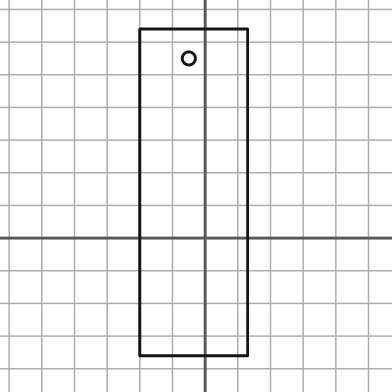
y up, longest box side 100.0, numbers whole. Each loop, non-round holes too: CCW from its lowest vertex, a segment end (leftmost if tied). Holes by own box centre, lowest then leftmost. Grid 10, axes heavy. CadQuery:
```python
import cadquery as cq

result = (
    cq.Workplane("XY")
    .moveTo(-20.0, -36.0)
    .lineTo(13.0, -36.0)
    .lineTo(13.0, 64.0)
    .lineTo(-20.0, 64.0)
    .close()
    .moveTo(-5.0, 55.0)
    .circle(2.0)
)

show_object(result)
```